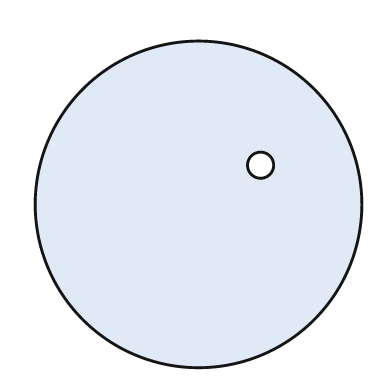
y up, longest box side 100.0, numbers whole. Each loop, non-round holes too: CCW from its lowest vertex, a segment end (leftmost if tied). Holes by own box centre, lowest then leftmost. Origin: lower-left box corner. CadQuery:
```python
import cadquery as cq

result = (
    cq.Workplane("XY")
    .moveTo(50.0, 50.0)
    .circle(50.0)
    .moveTo(69.0, 62.0)
    .circle(4.0)
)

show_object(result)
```